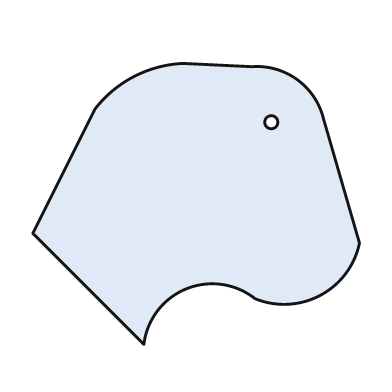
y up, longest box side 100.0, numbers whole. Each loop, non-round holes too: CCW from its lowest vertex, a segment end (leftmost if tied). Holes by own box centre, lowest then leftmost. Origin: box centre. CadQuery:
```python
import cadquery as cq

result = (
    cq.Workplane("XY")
    .moveTo(-16.0, -43.0)
    .threePointArc((-3.0, -26.0), (18.0, -29.0))
    .threePointArc((38.0, -28.0), (50.0, -12.0))
    .lineTo(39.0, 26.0)
    .threePointArc((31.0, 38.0), (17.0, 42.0))
    .lineTo(-4.0, 43.0)
    .threePointArc((-19.0, 39.0), (-31.0, 29.0))
    .lineTo(-50.0, -9.0)
    .close()
    .moveTo(23.0, 25.0)
    .circle(2.0)
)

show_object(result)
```